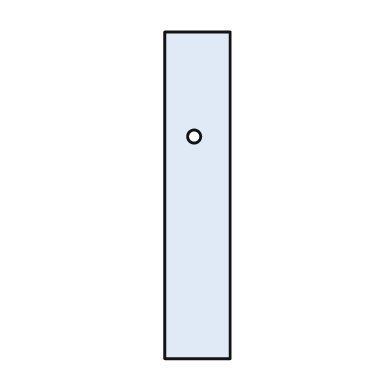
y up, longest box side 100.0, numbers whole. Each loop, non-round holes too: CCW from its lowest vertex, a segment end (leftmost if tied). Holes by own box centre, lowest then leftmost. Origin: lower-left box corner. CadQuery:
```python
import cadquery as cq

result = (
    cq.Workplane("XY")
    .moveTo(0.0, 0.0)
    .lineTo(20.0, 0.0)
    .lineTo(20.0, 100.0)
    .lineTo(0.0, 100.0)
    .close()
    .moveTo(9.0, 68.0)
    .circle(2.0)
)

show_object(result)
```